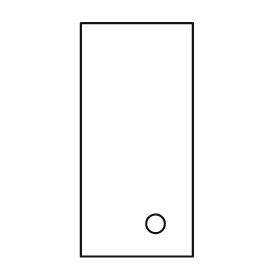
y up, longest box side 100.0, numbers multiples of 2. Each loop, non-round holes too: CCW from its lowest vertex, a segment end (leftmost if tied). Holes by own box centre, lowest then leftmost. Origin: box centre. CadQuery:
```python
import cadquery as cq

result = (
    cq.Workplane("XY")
    .moveTo(-24.0, -50.0)
    .lineTo(24.0, -50.0)
    .lineTo(24.0, 50.0)
    .lineTo(-24.0, 50.0)
    .close()
    .moveTo(8.0, -36.0)
    .circle(4.0)
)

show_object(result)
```